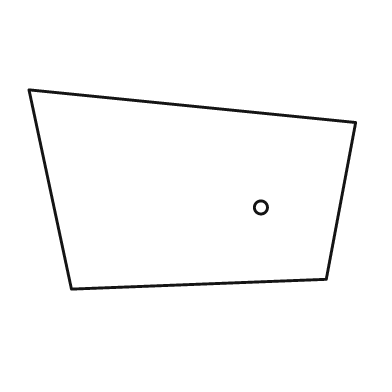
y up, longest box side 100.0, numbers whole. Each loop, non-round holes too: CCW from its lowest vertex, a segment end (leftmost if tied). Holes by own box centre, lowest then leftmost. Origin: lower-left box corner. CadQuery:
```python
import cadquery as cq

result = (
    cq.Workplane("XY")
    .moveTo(13.0, 0.0)
    .lineTo(91.0, 3.0)
    .lineTo(100.0, 51.0)
    .lineTo(0.0, 61.0)
    .close()
    .moveTo(71.0, 25.0)
    .circle(2.0)
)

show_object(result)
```